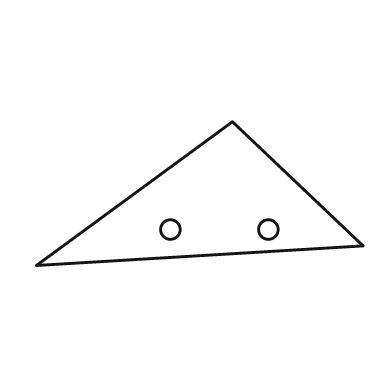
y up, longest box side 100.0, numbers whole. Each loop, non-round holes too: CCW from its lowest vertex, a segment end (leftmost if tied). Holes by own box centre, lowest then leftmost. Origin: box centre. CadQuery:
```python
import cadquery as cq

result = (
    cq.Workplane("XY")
    .moveTo(-50.0, -22.0)
    .lineTo(50.0, -16.0)
    .lineTo(10.0, 22.0)
    .close()
    .moveTo(-9.0, -11.0)
    .circle(3.0)
    .moveTo(21.0, -11.0)
    .circle(3.0)
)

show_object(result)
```